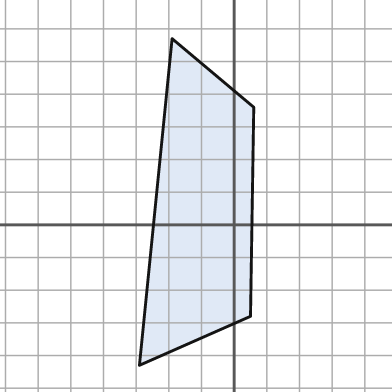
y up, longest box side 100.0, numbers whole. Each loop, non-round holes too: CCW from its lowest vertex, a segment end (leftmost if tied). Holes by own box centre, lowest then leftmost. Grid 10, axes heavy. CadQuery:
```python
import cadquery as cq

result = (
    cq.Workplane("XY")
    .moveTo(-29.0, -43.0)
    .lineTo(5.0, -28.0)
    .lineTo(6.0, 36.0)
    .lineTo(-19.0, 57.0)
    .close()
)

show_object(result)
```